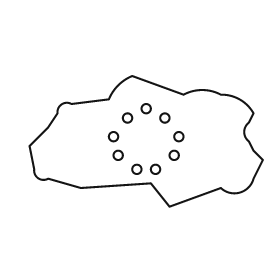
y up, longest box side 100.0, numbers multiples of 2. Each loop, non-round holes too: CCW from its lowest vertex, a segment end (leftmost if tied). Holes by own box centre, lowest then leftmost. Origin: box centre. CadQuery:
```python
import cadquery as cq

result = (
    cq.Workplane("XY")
    .moveTo(10.0, -28.0)
    .lineTo(32.0, -20.0)
    .threePointArc((40.0, -22.0), (46.0, -16.0))
    .lineTo(50.0, -8.0)
    .lineTo(46.0, -4.0)
    .lineTo(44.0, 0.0)
    .threePointArc((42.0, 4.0), (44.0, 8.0))
    .lineTo(46.0, 12.0)
    .threePointArc((40.0, 18.0), (32.0, 20.0))
    .threePointArc((24.0, 22.0), (16.0, 20.0))
    .lineTo(-6.0, 28.0)
    .threePointArc((-12.0, 24.0), (-16.0, 18.0))
    .lineTo(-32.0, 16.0)
    .threePointArc((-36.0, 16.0), (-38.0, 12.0))
    .lineTo(-42.0, 6.0)
    .lineTo(-50.0, -2.0)
    .lineTo(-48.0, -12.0)
    .threePointArc((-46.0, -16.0), (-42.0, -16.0))
    .lineTo(-28.0, -20.0)
    .lineTo(2.0, -18.0)
    .close()
    .moveTo(-4.0, -12.0)
    .circle(2.0)
    .moveTo(4.0, -12.0)
    .circle(2.0)
    .moveTo(-12.0, -6.0)
    .circle(2.0)
    .moveTo(12.0, -6.0)
    .circle(2.0)
    .moveTo(-14.0, 2.0)
    .circle(2.0)
    .moveTo(14.0, 2.0)
    .circle(2.0)
    .moveTo(-8.0, 10.0)
    .circle(2.0)
    .moveTo(8.0, 10.0)
    .circle(2.0)
    .moveTo(0.0, 14.0)
    .circle(2.0)
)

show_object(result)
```